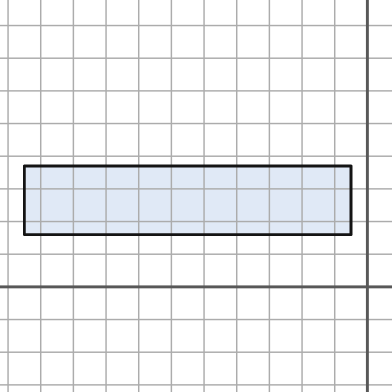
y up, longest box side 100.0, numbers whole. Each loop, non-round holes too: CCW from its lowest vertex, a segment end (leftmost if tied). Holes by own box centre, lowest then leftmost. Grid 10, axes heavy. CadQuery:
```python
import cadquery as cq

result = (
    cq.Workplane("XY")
    .moveTo(-105.0, 16.0)
    .lineTo(-5.0, 16.0)
    .lineTo(-5.0, 37.0)
    .lineTo(-105.0, 37.0)
    .close()
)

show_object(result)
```